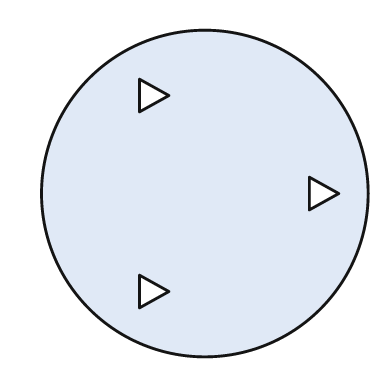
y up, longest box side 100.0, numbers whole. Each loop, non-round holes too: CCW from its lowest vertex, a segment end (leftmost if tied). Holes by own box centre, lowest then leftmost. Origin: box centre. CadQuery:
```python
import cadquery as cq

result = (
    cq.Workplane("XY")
    .moveTo(0.0, 0.0)
    .circle(50.0)
    .moveTo(-20.0, -35.0)
    .lineTo(-11.0, -30.0)
    .lineTo(-20.0, -25.0)
    .close()
    .moveTo(32.0, -5.0)
    .lineTo(41.0, 0.0)
    .lineTo(32.0, 5.0)
    .close()
    .moveTo(-20.0, 25.0)
    .lineTo(-11.0, 30.0)
    .lineTo(-20.0, 35.0)
    .close()
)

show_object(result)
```